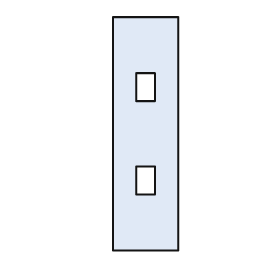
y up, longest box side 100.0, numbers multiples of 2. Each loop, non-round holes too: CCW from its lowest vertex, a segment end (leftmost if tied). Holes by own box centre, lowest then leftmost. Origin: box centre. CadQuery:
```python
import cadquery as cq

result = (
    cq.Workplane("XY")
    .moveTo(-14.0, -50.0)
    .lineTo(14.0, -50.0)
    .lineTo(14.0, 50.0)
    .lineTo(-14.0, 50.0)
    .close()
    .moveTo(-4.0, -26.0)
    .lineTo(4.0, -26.0)
    .lineTo(4.0, -14.0)
    .lineTo(-4.0, -14.0)
    .close()
    .moveTo(-4.0, 14.0)
    .lineTo(4.0, 14.0)
    .lineTo(4.0, 26.0)
    .lineTo(-4.0, 26.0)
    .close()
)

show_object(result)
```